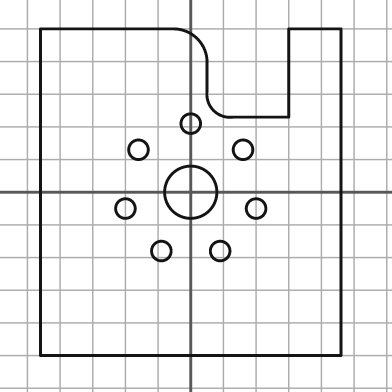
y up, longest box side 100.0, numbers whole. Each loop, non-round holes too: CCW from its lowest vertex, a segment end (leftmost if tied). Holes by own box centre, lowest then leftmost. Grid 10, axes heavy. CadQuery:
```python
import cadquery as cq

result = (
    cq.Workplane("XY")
    .moveTo(-46.0, -50.0)
    .lineTo(46.0, -50.0)
    .lineTo(46.0, 50.0)
    .lineTo(30.0, 50.0)
    .lineTo(30.0, 23.0)
    .lineTo(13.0, 23.0)
    .threePointArc((7.0, 25.0), (5.0, 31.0))
    .lineTo(5.0, 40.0)
    .threePointArc((2.0, 47.0), (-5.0, 50.0))
    .lineTo(-46.0, 50.0)
    .close()
    .moveTo(-9.0, -18.0)
    .circle(3.0)
    .moveTo(9.0, -18.0)
    .circle(3.0)
    .moveTo(-20.0, -5.0)
    .circle(3.0)
    .moveTo(20.0, -5.0)
    .circle(3.0)
    .moveTo(0.0, 0.0)
    .circle(8.0)
    .moveTo(-16.0, 13.0)
    .circle(3.0)
    .moveTo(16.0, 13.0)
    .circle(3.0)
    .moveTo(0.0, 21.0)
    .circle(3.0)
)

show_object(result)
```